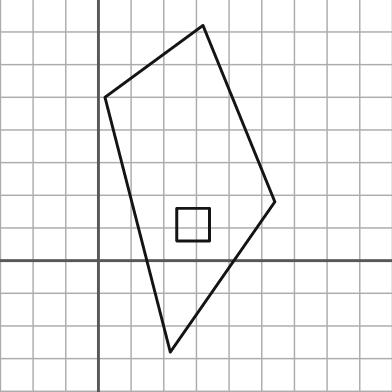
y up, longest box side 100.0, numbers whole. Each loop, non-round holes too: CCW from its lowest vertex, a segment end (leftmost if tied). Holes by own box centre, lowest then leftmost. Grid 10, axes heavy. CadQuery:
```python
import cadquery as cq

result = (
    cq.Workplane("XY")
    .moveTo(22.0, -28.0)
    .lineTo(54.0, 18.0)
    .lineTo(32.0, 72.0)
    .lineTo(2.0, 50.0)
    .close()
    .moveTo(24.0, 6.0)
    .lineTo(34.0, 6.0)
    .lineTo(34.0, 16.0)
    .lineTo(24.0, 16.0)
    .close()
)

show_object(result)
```